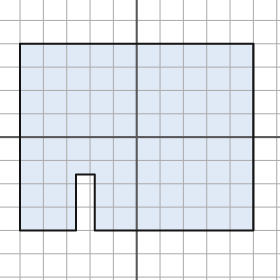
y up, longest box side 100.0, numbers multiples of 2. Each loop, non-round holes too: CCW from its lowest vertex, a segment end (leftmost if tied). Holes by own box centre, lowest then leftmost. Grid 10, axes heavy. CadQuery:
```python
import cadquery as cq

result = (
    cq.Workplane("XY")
    .moveTo(-50.0, -40.0)
    .lineTo(-26.0, -40.0)
    .lineTo(-26.0, -16.0)
    .lineTo(-18.0, -16.0)
    .lineTo(-18.0, -40.0)
    .lineTo(50.0, -40.0)
    .lineTo(50.0, 40.0)
    .lineTo(-50.0, 40.0)
    .close()
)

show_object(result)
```